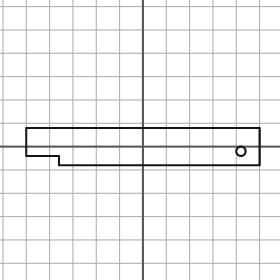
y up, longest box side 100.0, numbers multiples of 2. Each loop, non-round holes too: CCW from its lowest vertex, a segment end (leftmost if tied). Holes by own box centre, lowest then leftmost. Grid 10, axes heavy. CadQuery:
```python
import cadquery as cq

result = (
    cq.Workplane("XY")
    .moveTo(-36.0, -8.0)
    .lineTo(50.0, -8.0)
    .lineTo(50.0, 8.0)
    .lineTo(-50.0, 8.0)
    .lineTo(-50.0, -4.0)
    .lineTo(-36.0, -4.0)
    .close()
    .moveTo(42.0, -2.0)
    .circle(2.0)
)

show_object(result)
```